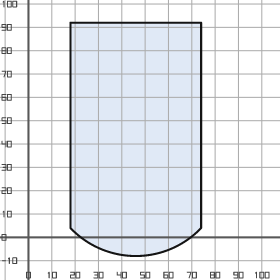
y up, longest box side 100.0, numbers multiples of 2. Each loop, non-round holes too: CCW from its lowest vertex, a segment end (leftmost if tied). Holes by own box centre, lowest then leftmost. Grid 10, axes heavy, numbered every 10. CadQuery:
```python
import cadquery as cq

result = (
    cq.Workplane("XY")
    .moveTo(18.0, 4.0)
    .threePointArc((46.0, -8.0), (74.0, 4.0))
    .lineTo(74.0, 92.0)
    .lineTo(18.0, 92.0)
    .close()
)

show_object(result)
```